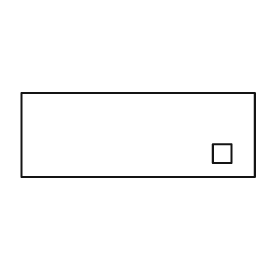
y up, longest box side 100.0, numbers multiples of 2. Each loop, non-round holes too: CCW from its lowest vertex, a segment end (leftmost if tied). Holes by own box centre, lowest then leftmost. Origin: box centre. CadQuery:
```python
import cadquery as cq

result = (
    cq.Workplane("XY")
    .moveTo(-50.0, -18.0)
    .lineTo(50.0, -18.0)
    .lineTo(50.0, 18.0)
    .lineTo(-50.0, 18.0)
    .close()
    .moveTo(32.0, -12.0)
    .lineTo(40.0, -12.0)
    .lineTo(40.0, -4.0)
    .lineTo(32.0, -4.0)
    .close()
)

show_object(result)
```